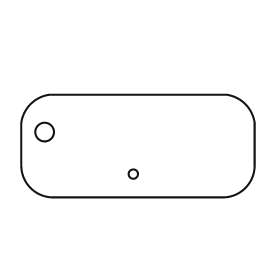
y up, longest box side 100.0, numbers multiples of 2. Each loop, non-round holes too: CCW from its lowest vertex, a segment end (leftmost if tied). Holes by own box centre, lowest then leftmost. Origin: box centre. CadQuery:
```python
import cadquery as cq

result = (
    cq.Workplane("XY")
    .moveTo(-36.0, -22.0)
    .lineTo(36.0, -22.0)
    .threePointArc((46.0, -18.0), (50.0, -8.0))
    .lineTo(50.0, 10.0)
    .threePointArc((46.0, 18.0), (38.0, 22.0))
    .lineTo(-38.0, 22.0)
    .threePointArc((-46.0, 18.0), (-50.0, 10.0))
    .lineTo(-50.0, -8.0)
    .threePointArc((-46.0, -18.0), (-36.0, -22.0))
    .close()
    .moveTo(-2.0, -12.0)
    .circle(2.0)
    .moveTo(-40.0, 6.0)
    .circle(4.0)
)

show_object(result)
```